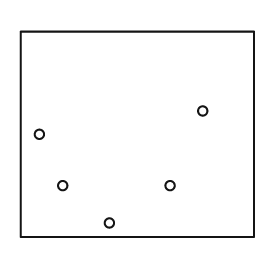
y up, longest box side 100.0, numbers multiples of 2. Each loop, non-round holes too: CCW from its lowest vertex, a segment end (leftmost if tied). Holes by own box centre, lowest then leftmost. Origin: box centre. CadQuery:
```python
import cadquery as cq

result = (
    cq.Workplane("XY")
    .moveTo(-50.0, -44.0)
    .lineTo(50.0, -44.0)
    .lineTo(50.0, 44.0)
    .lineTo(-50.0, 44.0)
    .close()
    .moveTo(-12.0, -38.0)
    .circle(2.0)
    .moveTo(-32.0, -22.0)
    .circle(2.0)
    .moveTo(14.0, -22.0)
    .circle(2.0)
    .moveTo(-42.0, 0.0)
    .circle(2.0)
    .moveTo(28.0, 10.0)
    .circle(2.0)
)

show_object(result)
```